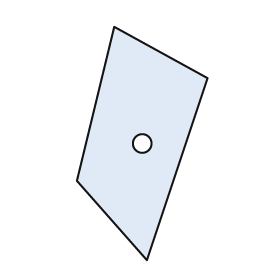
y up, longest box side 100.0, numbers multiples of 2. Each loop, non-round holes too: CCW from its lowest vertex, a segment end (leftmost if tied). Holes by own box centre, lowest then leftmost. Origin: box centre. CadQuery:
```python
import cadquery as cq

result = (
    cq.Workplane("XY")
    .moveTo(2.0, -50.0)
    .lineTo(28.0, 28.0)
    .lineTo(-12.0, 50.0)
    .lineTo(-28.0, -16.0)
    .close()
    .moveTo(0.0, 0.0)
    .circle(4.0)
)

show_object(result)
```